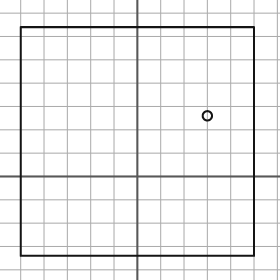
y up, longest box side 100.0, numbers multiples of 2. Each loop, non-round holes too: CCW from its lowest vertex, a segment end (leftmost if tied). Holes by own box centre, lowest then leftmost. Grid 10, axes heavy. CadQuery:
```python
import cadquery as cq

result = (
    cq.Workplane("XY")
    .moveTo(-50.0, -34.0)
    .lineTo(50.0, -34.0)
    .lineTo(50.0, 64.0)
    .lineTo(-50.0, 64.0)
    .close()
    .moveTo(30.0, 26.0)
    .circle(2.0)
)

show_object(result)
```